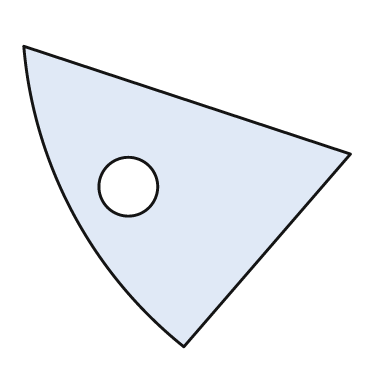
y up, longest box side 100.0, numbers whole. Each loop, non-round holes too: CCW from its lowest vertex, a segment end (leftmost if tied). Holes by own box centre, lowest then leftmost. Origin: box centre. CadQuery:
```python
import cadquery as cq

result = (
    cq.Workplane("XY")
    .moveTo(-1.0, -46.0)
    .lineTo(50.0, 13.0)
    .lineTo(-50.0, 46.0)
    .threePointArc((-35.0, -5.0), (-1.0, -46.0))
    .close()
    .moveTo(-18.0, 3.0)
    .circle(9.0)
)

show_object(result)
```